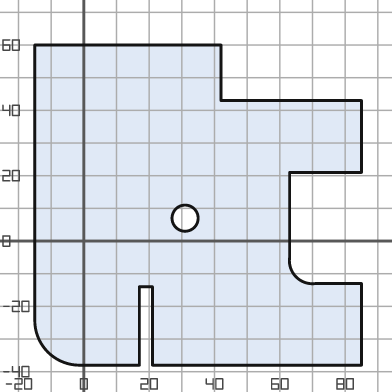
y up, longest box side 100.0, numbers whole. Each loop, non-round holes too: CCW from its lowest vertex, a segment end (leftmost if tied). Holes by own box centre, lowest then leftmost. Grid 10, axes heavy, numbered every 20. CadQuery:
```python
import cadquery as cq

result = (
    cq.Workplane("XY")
    .moveTo(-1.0, -38.0)
    .lineTo(17.0, -38.0)
    .lineTo(17.0, -14.0)
    .lineTo(21.0, -14.0)
    .lineTo(21.0, -38.0)
    .lineTo(85.0, -38.0)
    .lineTo(85.0, -13.0)
    .lineTo(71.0, -13.0)
    .threePointArc((65.0, -11.0), (63.0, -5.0))
    .lineTo(63.0, 21.0)
    .lineTo(85.0, 21.0)
    .lineTo(85.0, 43.0)
    .lineTo(42.0, 43.0)
    .lineTo(42.0, 60.0)
    .lineTo(-15.0, 60.0)
    .lineTo(-15.0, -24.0)
    .threePointArc((-11.0, -34.0), (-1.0, -38.0))
    .close()
    .moveTo(31.0, 7.0)
    .circle(4.0)
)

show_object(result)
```